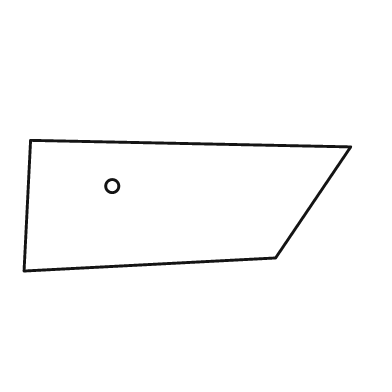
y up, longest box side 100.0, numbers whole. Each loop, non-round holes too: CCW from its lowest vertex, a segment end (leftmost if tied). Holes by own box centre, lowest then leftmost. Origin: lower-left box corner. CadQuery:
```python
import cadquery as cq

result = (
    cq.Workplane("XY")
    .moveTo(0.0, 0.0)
    .lineTo(77.0, 4.0)
    .lineTo(100.0, 38.0)
    .lineTo(2.0, 40.0)
    .close()
    .moveTo(27.0, 26.0)
    .circle(2.0)
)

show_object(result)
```